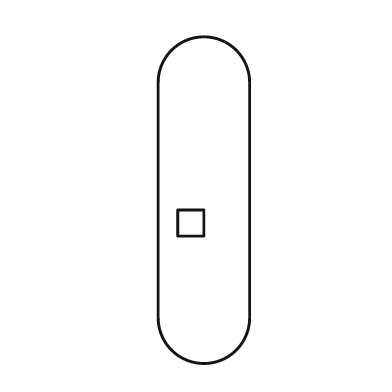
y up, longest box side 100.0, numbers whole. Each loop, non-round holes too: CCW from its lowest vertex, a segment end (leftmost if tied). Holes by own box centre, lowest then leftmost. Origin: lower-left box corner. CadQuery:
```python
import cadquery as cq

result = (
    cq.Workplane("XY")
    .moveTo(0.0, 14.0)
    .threePointArc((14.0, 0.0), (28.0, 14.0))
    .lineTo(28.0, 86.0)
    .threePointArc((14.0, 100.0), (0.0, 86.0))
    .close()
    .moveTo(6.0, 39.0)
    .lineTo(14.0, 39.0)
    .lineTo(14.0, 47.0)
    .lineTo(6.0, 47.0)
    .close()
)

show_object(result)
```